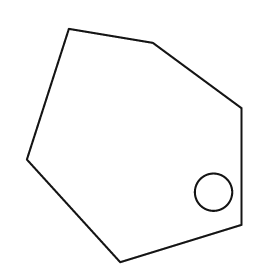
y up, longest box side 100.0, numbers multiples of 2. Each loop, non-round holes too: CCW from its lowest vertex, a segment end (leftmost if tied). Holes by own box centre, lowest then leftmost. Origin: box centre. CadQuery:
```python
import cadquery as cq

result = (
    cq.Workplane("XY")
    .moveTo(-6.0, -50.0)
    .lineTo(46.0, -34.0)
    .lineTo(46.0, 16.0)
    .lineTo(8.0, 44.0)
    .lineTo(-28.0, 50.0)
    .lineTo(-46.0, -6.0)
    .close()
    .moveTo(34.0, -20.0)
    .circle(8.0)
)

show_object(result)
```